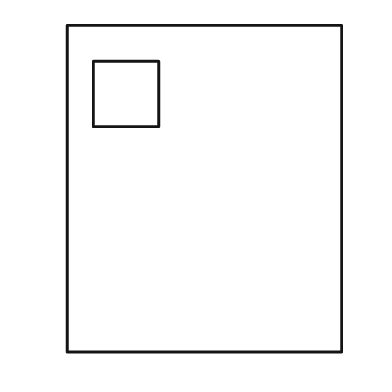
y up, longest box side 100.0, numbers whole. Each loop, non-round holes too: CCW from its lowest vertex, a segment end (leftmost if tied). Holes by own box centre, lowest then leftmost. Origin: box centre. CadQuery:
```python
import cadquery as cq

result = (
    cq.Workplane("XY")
    .moveTo(-42.0, -50.0)
    .lineTo(42.0, -50.0)
    .lineTo(42.0, 50.0)
    .lineTo(-42.0, 50.0)
    .close()
    .moveTo(-34.0, 19.0)
    .lineTo(-14.0, 19.0)
    .lineTo(-14.0, 39.0)
    .lineTo(-34.0, 39.0)
    .close()
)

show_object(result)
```